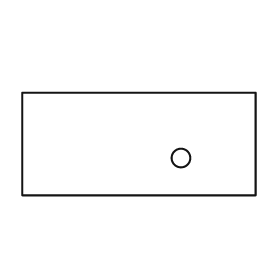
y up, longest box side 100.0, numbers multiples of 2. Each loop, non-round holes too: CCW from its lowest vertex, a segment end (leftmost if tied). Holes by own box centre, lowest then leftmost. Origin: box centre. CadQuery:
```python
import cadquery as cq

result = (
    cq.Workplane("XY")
    .moveTo(-50.0, -22.0)
    .lineTo(50.0, -22.0)
    .lineTo(50.0, 22.0)
    .lineTo(-50.0, 22.0)
    .close()
    .moveTo(18.0, -6.0)
    .circle(4.0)
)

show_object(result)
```